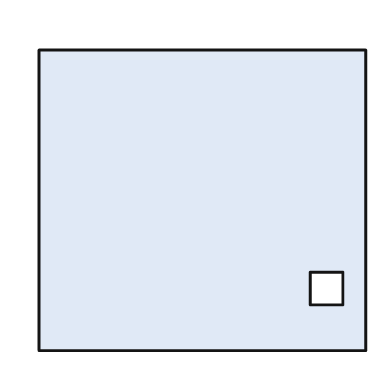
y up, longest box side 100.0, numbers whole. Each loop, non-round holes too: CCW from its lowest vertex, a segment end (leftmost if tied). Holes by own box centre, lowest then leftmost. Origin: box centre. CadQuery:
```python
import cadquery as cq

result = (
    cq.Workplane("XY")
    .moveTo(-50.0, -46.0)
    .lineTo(50.0, -46.0)
    .lineTo(50.0, 46.0)
    .lineTo(-50.0, 46.0)
    .close()
    .moveTo(33.0, -32.0)
    .lineTo(43.0, -32.0)
    .lineTo(43.0, -22.0)
    .lineTo(33.0, -22.0)
    .close()
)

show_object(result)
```